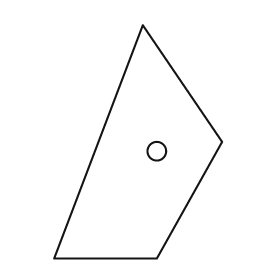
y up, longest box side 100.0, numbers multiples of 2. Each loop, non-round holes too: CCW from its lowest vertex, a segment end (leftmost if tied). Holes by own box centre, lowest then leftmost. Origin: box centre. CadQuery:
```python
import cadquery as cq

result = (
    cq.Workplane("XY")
    .moveTo(-36.0, -50.0)
    .lineTo(8.0, -50.0)
    .lineTo(36.0, 0.0)
    .lineTo(2.0, 50.0)
    .close()
    .moveTo(8.0, -4.0)
    .circle(4.0)
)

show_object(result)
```